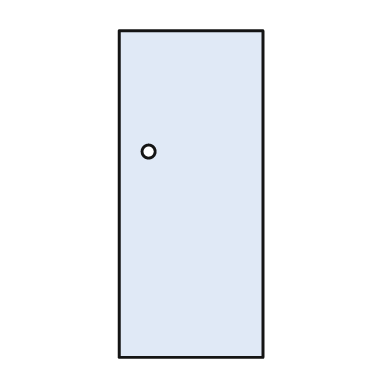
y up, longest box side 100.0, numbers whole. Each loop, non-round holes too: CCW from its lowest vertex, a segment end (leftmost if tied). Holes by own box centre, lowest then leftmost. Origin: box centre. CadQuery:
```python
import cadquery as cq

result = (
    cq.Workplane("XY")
    .moveTo(-22.0, -50.0)
    .lineTo(22.0, -50.0)
    .lineTo(22.0, 50.0)
    .lineTo(-22.0, 50.0)
    .close()
    .moveTo(-13.0, 13.0)
    .circle(2.0)
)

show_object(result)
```